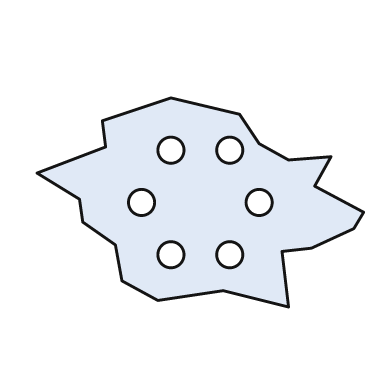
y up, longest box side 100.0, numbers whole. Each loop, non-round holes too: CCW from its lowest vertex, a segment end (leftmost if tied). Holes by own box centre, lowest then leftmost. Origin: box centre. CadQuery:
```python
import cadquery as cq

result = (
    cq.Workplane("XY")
    .moveTo(27.0, -32.0)
    .lineTo(25.0, -15.0)
    .lineTo(34.0, -14.0)
    .lineTo(47.0, -8.0)
    .lineTo(50.0, -3.0)
    .lineTo(35.0, 5.0)
    .lineTo(40.0, 14.0)
    .lineTo(27.0, 13.0)
    .lineTo(18.0, 18.0)
    .lineTo(12.0, 27.0)
    .lineTo(-9.0, 32.0)
    .lineTo(-30.0, 25.0)
    .lineTo(-29.0, 17.0)
    .lineTo(-50.0, 9.0)
    .lineTo(-37.0, 1.0)
    .lineTo(-36.0, -6.0)
    .lineTo(-26.0, -13.0)
    .lineTo(-24.0, -24.0)
    .lineTo(-13.0, -30.0)
    .lineTo(7.0, -27.0)
    .close()
    .moveTo(-9.0, -16.0)
    .circle(4.0)
    .moveTo(9.0, -16.0)
    .circle(4.0)
    .moveTo(-18.0, 0.0)
    .circle(4.0)
    .moveTo(18.0, 0.0)
    .circle(4.0)
    .moveTo(-9.0, 16.0)
    .circle(4.0)
    .moveTo(9.0, 16.0)
    .circle(4.0)
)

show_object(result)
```